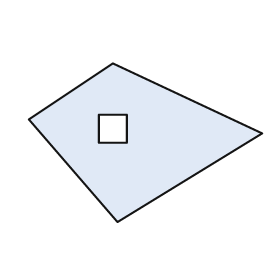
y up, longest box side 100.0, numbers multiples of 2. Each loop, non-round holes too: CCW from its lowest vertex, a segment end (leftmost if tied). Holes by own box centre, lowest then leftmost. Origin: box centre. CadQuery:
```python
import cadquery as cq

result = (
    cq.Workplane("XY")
    .moveTo(-12.0, -34.0)
    .lineTo(50.0, 4.0)
    .lineTo(-14.0, 34.0)
    .lineTo(-50.0, 10.0)
    .close()
    .moveTo(-20.0, 0.0)
    .lineTo(-8.0, 0.0)
    .lineTo(-8.0, 12.0)
    .lineTo(-20.0, 12.0)
    .close()
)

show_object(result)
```